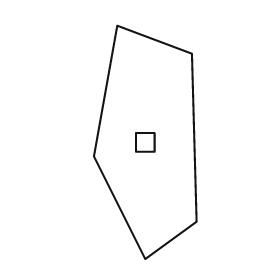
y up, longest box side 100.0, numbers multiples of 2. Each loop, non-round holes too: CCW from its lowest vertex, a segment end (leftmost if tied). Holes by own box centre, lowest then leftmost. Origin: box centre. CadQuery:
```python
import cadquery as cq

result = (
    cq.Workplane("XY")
    .moveTo(0.0, -50.0)
    .lineTo(22.0, -34.0)
    .lineTo(20.0, 38.0)
    .lineTo(-12.0, 50.0)
    .lineTo(-22.0, -6.0)
    .close()
    .moveTo(-4.0, -4.0)
    .lineTo(4.0, -4.0)
    .lineTo(4.0, 4.0)
    .lineTo(-4.0, 4.0)
    .close()
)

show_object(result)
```